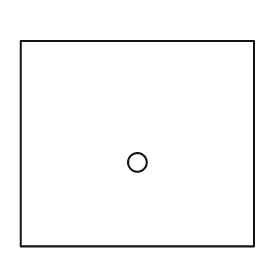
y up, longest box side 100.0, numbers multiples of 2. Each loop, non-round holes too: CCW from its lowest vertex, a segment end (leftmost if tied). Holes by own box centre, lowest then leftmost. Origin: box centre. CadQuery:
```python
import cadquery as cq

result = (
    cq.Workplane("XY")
    .moveTo(-50.0, -44.0)
    .lineTo(50.0, -44.0)
    .lineTo(50.0, 44.0)
    .lineTo(-50.0, 44.0)
    .close()
    .moveTo(0.0, -8.0)
    .circle(4.0)
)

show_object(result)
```